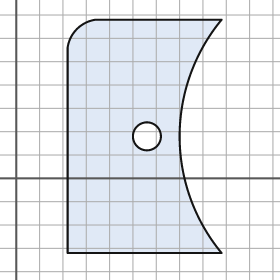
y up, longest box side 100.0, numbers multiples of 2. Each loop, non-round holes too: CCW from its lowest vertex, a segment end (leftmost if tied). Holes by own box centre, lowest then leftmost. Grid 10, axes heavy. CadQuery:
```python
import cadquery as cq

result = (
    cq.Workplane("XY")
    .moveTo(22.0, -32.0)
    .lineTo(88.0, -32.0)
    .threePointArc((70.0, 18.0), (88.0, 68.0))
    .lineTo(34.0, 68.0)
    .threePointArc((26.0, 64.0), (22.0, 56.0))
    .close()
    .moveTo(56.0, 18.0)
    .circle(6.0)
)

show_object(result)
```